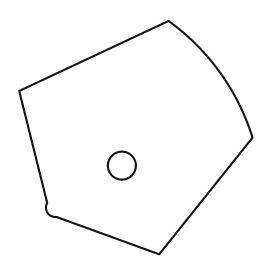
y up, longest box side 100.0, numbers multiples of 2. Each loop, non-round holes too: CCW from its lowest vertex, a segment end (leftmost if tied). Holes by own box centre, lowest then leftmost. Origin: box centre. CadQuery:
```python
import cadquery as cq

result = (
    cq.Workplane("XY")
    .moveTo(10.0, -50.0)
    .lineTo(50.0, 0.0)
    .threePointArc((36.0, 28.0), (14.0, 50.0))
    .lineTo(-50.0, 20.0)
    .lineTo(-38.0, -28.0)
    .threePointArc((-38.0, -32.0), (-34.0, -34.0))
    .close()
    .moveTo(-6.0, -12.0)
    .circle(6.0)
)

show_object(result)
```